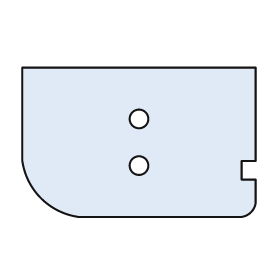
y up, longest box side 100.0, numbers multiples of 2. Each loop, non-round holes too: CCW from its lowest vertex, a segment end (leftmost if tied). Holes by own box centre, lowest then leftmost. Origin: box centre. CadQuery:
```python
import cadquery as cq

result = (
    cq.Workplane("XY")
    .moveTo(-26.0, -32.0)
    .lineTo(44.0, -32.0)
    .threePointArc((48.0, -30.0), (50.0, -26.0))
    .lineTo(50.0, -16.0)
    .lineTo(44.0, -16.0)
    .lineTo(44.0, -8.0)
    .lineTo(50.0, -8.0)
    .lineTo(50.0, 32.0)
    .lineTo(-50.0, 32.0)
    .lineTo(-50.0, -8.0)
    .threePointArc((-42.0, -24.0), (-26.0, -32.0))
    .close()
    .moveTo(0.0, -10.0)
    .circle(4.0)
    .moveTo(0.0, 10.0)
    .circle(4.0)
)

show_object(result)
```